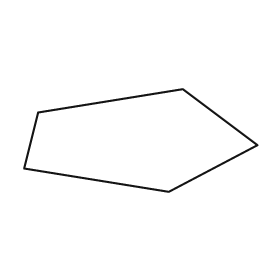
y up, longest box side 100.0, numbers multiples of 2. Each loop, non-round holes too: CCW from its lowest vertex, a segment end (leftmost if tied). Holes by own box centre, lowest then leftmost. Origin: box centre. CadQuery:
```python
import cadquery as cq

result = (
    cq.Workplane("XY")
    .moveTo(12.0, -22.0)
    .lineTo(50.0, -2.0)
    .lineTo(18.0, 22.0)
    .lineTo(-44.0, 12.0)
    .lineTo(-50.0, -12.0)
    .close()
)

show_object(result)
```